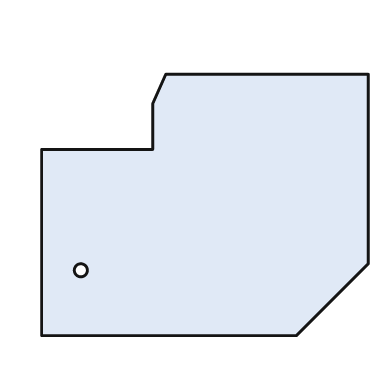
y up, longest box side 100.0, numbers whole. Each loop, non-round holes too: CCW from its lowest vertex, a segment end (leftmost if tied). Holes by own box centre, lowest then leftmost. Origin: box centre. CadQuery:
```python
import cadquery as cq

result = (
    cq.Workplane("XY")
    .moveTo(-50.0, -40.0)
    .lineTo(28.0, -40.0)
    .lineTo(50.0, -18.0)
    .lineTo(50.0, 40.0)
    .lineTo(-12.0, 40.0)
    .lineTo(-16.0, 31.0)
    .lineTo(-16.0, 17.0)
    .lineTo(-50.0, 17.0)
    .close()
    .moveTo(-38.0, -20.0)
    .circle(2.0)
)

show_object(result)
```